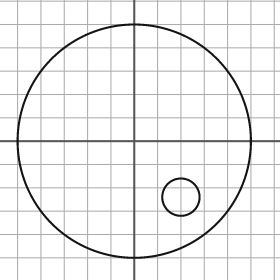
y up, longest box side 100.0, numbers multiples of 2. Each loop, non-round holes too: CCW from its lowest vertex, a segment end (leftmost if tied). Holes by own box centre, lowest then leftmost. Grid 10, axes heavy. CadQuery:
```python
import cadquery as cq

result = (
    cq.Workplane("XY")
    .moveTo(0.0, 0.0)
    .circle(50.0)
    .moveTo(20.0, -24.0)
    .circle(8.0)
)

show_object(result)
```